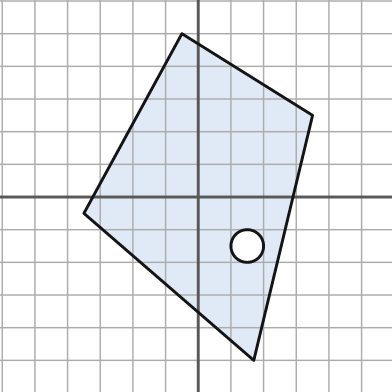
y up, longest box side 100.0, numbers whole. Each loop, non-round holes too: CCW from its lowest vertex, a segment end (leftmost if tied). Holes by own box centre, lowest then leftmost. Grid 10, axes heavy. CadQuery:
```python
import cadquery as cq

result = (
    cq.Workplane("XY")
    .moveTo(17.0, -50.0)
    .lineTo(35.0, 25.0)
    .lineTo(-5.0, 50.0)
    .lineTo(-35.0, -5.0)
    .close()
    .moveTo(15.0, -15.0)
    .circle(5.0)
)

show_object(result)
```